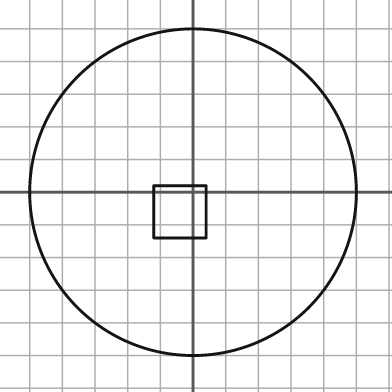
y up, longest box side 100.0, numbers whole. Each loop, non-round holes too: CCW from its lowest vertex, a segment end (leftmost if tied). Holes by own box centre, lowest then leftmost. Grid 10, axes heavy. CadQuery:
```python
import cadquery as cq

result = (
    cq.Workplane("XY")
    .moveTo(0.0, 0.0)
    .circle(50.0)
    .moveTo(-12.0, -14.0)
    .lineTo(4.0, -14.0)
    .lineTo(4.0, 2.0)
    .lineTo(-12.0, 2.0)
    .close()
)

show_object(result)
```